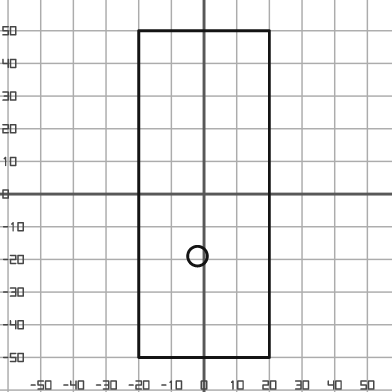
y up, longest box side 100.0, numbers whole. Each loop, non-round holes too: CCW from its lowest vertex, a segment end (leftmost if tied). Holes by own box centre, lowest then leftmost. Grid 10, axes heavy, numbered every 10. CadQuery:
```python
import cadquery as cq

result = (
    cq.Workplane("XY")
    .moveTo(-20.0, -50.0)
    .lineTo(20.0, -50.0)
    .lineTo(20.0, 50.0)
    .lineTo(-20.0, 50.0)
    .close()
    .moveTo(-2.0, -19.0)
    .circle(3.0)
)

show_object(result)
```